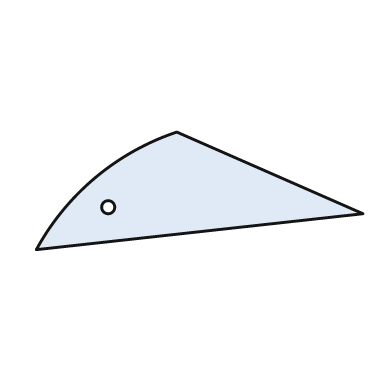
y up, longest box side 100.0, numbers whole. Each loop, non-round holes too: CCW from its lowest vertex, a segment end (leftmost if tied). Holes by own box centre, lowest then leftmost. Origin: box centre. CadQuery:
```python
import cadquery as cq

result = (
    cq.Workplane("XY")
    .moveTo(-50.0, -18.0)
    .lineTo(50.0, -7.0)
    .lineTo(-7.0, 18.0)
    .threePointArc((-32.0, 4.0), (-50.0, -18.0))
    .close()
    .moveTo(-28.0, -5.0)
    .circle(2.0)
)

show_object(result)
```